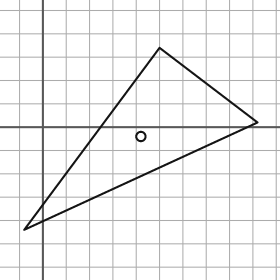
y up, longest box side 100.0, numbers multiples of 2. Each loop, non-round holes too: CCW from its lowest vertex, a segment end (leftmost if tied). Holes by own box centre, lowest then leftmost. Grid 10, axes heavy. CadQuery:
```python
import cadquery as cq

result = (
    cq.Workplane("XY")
    .moveTo(-8.0, -44.0)
    .lineTo(92.0, 2.0)
    .lineTo(50.0, 34.0)
    .close()
    .moveTo(42.0, -4.0)
    .circle(2.0)
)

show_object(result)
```